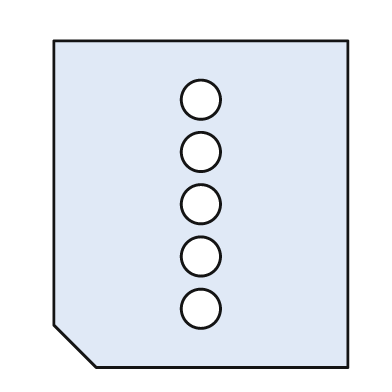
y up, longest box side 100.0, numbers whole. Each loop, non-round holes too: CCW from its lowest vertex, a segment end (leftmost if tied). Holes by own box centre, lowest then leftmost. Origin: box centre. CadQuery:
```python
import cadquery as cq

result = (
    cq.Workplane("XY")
    .moveTo(-32.0, -50.0)
    .lineTo(45.0, -50.0)
    .lineTo(45.0, 50.0)
    .lineTo(-45.0, 50.0)
    .lineTo(-45.0, -37.0)
    .close()
    .moveTo(0.0, -32.0)
    .circle(6.0)
    .moveTo(0.0, -16.0)
    .circle(6.0)
    .moveTo(0.0, 0.0)
    .circle(6.0)
    .moveTo(0.0, 16.0)
    .circle(6.0)
    .moveTo(0.0, 32.0)
    .circle(6.0)
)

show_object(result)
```